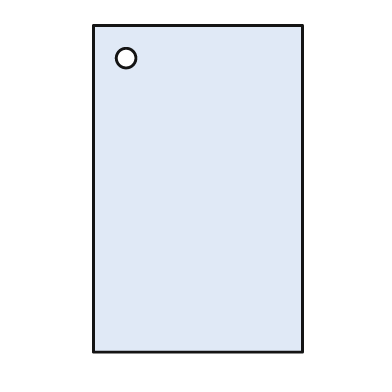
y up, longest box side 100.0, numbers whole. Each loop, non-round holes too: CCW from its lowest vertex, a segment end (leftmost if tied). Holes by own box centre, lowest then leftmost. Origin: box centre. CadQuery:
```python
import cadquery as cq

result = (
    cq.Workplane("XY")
    .moveTo(-32.0, -50.0)
    .lineTo(32.0, -50.0)
    .lineTo(32.0, 50.0)
    .lineTo(-32.0, 50.0)
    .close()
    .moveTo(-22.0, 40.0)
    .circle(3.0)
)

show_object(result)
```